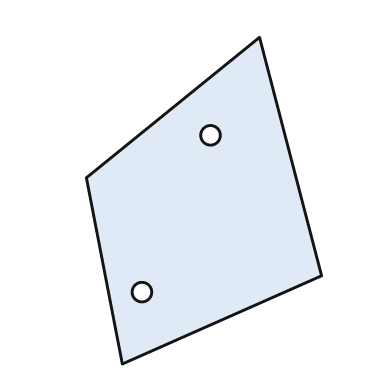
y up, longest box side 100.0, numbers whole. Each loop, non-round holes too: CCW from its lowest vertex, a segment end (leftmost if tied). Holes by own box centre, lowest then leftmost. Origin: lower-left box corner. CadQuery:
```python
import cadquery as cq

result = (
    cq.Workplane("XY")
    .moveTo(11.0, 0.0)
    .lineTo(72.0, 27.0)
    .lineTo(53.0, 100.0)
    .lineTo(0.0, 57.0)
    .close()
    .moveTo(17.0, 22.0)
    .circle(3.0)
    .moveTo(38.0, 70.0)
    .circle(3.0)
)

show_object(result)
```